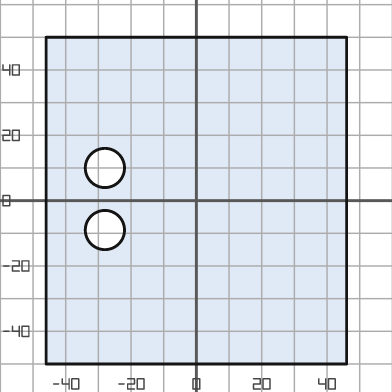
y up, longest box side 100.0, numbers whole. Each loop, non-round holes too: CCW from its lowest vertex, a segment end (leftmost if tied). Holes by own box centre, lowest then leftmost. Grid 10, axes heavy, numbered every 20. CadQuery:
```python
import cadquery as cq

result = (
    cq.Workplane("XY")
    .moveTo(-46.0, -50.0)
    .lineTo(46.0, -50.0)
    .lineTo(46.0, 50.0)
    .lineTo(-46.0, 50.0)
    .close()
    .moveTo(-28.0, -9.0)
    .circle(6.0)
    .moveTo(-28.0, 10.0)
    .circle(6.0)
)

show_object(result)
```